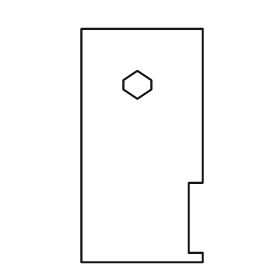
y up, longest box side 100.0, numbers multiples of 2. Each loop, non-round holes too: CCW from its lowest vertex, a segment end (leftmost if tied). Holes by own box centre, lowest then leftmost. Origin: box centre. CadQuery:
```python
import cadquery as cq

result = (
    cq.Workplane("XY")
    .moveTo(-26.0, -50.0)
    .lineTo(26.0, -50.0)
    .lineTo(26.0, -46.0)
    .lineTo(20.0, -46.0)
    .lineTo(20.0, -16.0)
    .lineTo(26.0, -16.0)
    .lineTo(26.0, 50.0)
    .lineTo(-26.0, 50.0)
    .close()
    .moveTo(-2.0, 20.0)
    .lineTo(4.0, 24.0)
    .lineTo(4.0, 28.0)
    .lineTo(-2.0, 32.0)
    .lineTo(-8.0, 28.0)
    .lineTo(-8.0, 24.0)
    .close()
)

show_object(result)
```